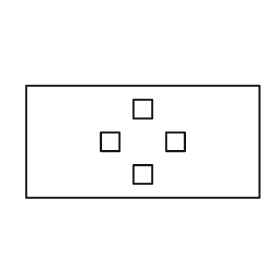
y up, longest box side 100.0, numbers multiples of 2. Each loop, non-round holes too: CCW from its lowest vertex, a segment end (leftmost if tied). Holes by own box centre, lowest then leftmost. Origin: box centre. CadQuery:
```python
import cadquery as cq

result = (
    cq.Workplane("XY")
    .moveTo(-50.0, -24.0)
    .lineTo(50.0, -24.0)
    .lineTo(50.0, 24.0)
    .lineTo(-50.0, 24.0)
    .close()
    .moveTo(-4.0, -18.0)
    .lineTo(4.0, -18.0)
    .lineTo(4.0, -10.0)
    .lineTo(-4.0, -10.0)
    .close()
    .moveTo(-18.0, -4.0)
    .lineTo(-10.0, -4.0)
    .lineTo(-10.0, 4.0)
    .lineTo(-18.0, 4.0)
    .close()
    .moveTo(10.0, -4.0)
    .lineTo(18.0, -4.0)
    .lineTo(18.0, 4.0)
    .lineTo(10.0, 4.0)
    .close()
    .moveTo(-4.0, 10.0)
    .lineTo(4.0, 10.0)
    .lineTo(4.0, 18.0)
    .lineTo(-4.0, 18.0)
    .close()
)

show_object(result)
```